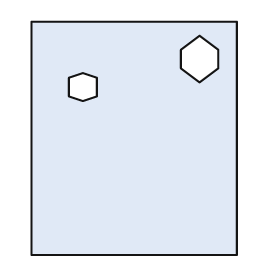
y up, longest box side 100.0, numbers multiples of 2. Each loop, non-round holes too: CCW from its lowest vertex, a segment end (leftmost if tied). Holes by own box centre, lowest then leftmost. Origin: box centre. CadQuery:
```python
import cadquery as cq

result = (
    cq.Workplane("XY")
    .moveTo(-44.0, -50.0)
    .lineTo(44.0, -50.0)
    .lineTo(44.0, 50.0)
    .lineTo(-44.0, 50.0)
    .close()
    .moveTo(-22.0, 16.0)
    .lineTo(-16.0, 18.0)
    .lineTo(-16.0, 26.0)
    .lineTo(-22.0, 28.0)
    .lineTo(-28.0, 26.0)
    .lineTo(-28.0, 18.0)
    .close()
    .moveTo(28.0, 24.0)
    .lineTo(36.0, 30.0)
    .lineTo(36.0, 38.0)
    .lineTo(28.0, 44.0)
    .lineTo(20.0, 38.0)
    .lineTo(20.0, 30.0)
    .close()
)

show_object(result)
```